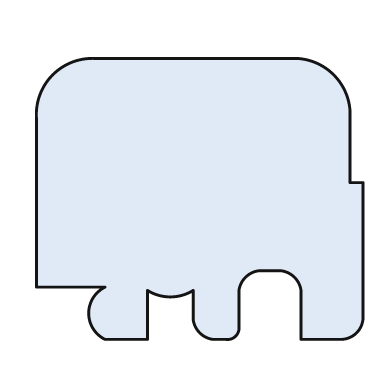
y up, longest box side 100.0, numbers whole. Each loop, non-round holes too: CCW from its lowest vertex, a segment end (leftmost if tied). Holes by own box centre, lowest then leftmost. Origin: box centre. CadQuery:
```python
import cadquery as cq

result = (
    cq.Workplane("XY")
    .moveTo(-29.0, -43.0)
    .lineTo(-16.0, -43.0)
    .lineTo(-16.0, -28.0)
    .threePointArc((-9.0, -30.0), (-2.0, -28.0))
    .lineTo(-2.0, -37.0)
    .threePointArc((0.0, -41.0), (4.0, -43.0))
    .lineTo(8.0, -43.0)
    .threePointArc((11.0, -42.0), (12.0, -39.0))
    .lineTo(12.0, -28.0)
    .threePointArc((14.0, -24.0), (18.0, -22.0))
    .lineTo(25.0, -22.0)
    .threePointArc((29.0, -24.0), (31.0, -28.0))
    .lineTo(31.0, -43.0)
    .lineTo(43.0, -43.0)
    .threePointArc((48.0, -41.0), (50.0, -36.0))
    .lineTo(50.0, 5.0)
    .lineTo(46.0, 5.0)
    .lineTo(46.0, 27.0)
    .threePointArc((41.0, 38.0), (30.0, 43.0))
    .lineTo(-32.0, 43.0)
    .threePointArc((-45.0, 38.0), (-50.0, 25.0))
    .lineTo(-50.0, -27.0)
    .lineTo(-29.0, -27.0)
    .threePointArc((-34.0, -35.0), (-29.0, -43.0))
    .close()
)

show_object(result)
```